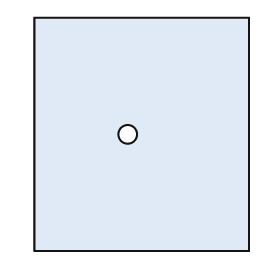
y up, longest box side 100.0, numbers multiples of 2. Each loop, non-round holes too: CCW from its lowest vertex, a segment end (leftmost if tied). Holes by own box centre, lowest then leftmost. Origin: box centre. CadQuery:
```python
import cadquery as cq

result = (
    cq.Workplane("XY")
    .moveTo(-46.0, -50.0)
    .lineTo(46.0, -50.0)
    .lineTo(46.0, 50.0)
    .lineTo(-46.0, 50.0)
    .close()
    .moveTo(-6.0, 0.0)
    .circle(4.0)
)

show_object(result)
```